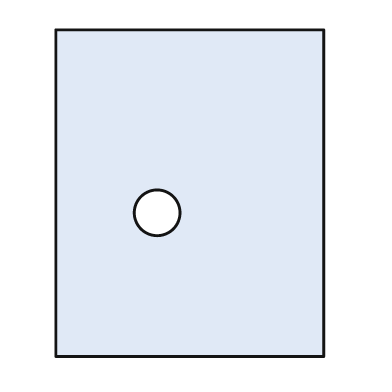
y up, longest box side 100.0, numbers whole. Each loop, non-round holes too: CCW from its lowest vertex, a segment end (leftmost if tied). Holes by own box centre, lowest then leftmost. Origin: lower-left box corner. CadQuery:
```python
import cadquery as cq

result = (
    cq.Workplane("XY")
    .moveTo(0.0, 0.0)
    .lineTo(82.0, 0.0)
    .lineTo(82.0, 100.0)
    .lineTo(0.0, 100.0)
    .close()
    .moveTo(31.0, 44.0)
    .circle(7.0)
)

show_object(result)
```